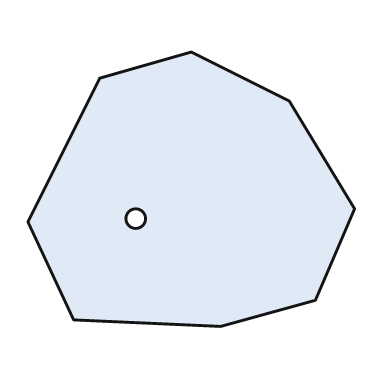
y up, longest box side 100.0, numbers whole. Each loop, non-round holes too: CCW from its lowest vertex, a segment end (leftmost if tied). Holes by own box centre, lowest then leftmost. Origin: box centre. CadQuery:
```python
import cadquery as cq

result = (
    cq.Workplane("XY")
    .moveTo(9.0, -42.0)
    .lineTo(38.0, -34.0)
    .lineTo(50.0, -6.0)
    .lineTo(30.0, 27.0)
    .lineTo(0.0, 42.0)
    .lineTo(-28.0, 34.0)
    .lineTo(-50.0, -10.0)
    .lineTo(-36.0, -40.0)
    .close()
    .moveTo(-17.0, -9.0)
    .circle(3.0)
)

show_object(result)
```